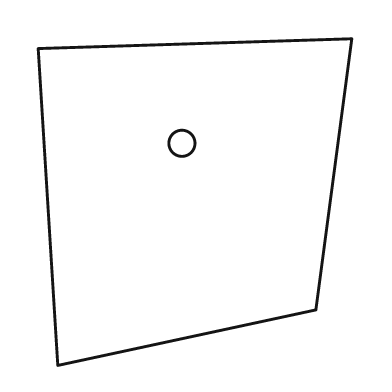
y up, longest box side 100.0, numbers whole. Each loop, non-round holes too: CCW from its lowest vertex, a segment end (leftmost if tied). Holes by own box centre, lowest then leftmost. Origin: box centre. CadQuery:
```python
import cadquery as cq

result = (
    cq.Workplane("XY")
    .moveTo(-42.0, -50.0)
    .lineTo(37.0, -33.0)
    .lineTo(48.0, 50.0)
    .lineTo(-48.0, 47.0)
    .close()
    .moveTo(-4.0, 18.0)
    .circle(4.0)
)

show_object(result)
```